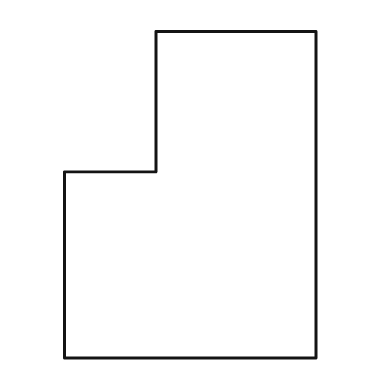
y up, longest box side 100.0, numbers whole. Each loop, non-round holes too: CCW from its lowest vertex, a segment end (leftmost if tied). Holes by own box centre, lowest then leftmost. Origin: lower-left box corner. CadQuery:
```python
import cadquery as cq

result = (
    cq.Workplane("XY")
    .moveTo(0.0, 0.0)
    .lineTo(77.0, 0.0)
    .lineTo(77.0, 100.0)
    .lineTo(28.0, 100.0)
    .lineTo(28.0, 57.0)
    .lineTo(0.0, 57.0)
    .close()
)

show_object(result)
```